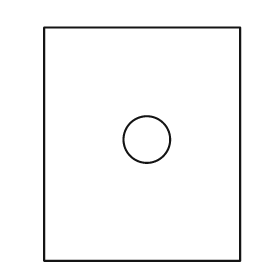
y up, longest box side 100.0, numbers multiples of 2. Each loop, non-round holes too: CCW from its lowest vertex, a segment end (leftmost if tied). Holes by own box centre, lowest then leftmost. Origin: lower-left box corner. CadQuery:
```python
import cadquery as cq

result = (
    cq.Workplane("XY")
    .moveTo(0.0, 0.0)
    .lineTo(84.0, 0.0)
    .lineTo(84.0, 100.0)
    .lineTo(0.0, 100.0)
    .close()
    .moveTo(44.0, 52.0)
    .circle(10.0)
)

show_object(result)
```